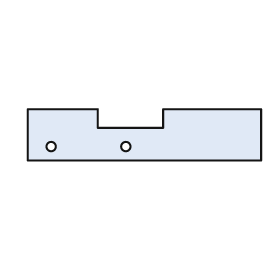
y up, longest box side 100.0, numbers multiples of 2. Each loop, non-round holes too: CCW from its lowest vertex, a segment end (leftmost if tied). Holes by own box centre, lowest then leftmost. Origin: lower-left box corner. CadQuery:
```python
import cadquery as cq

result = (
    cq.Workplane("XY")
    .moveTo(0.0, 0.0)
    .lineTo(100.0, 0.0)
    .lineTo(100.0, 22.0)
    .lineTo(58.0, 22.0)
    .lineTo(58.0, 14.0)
    .lineTo(30.0, 14.0)
    .lineTo(30.0, 22.0)
    .lineTo(0.0, 22.0)
    .close()
    .moveTo(10.0, 6.0)
    .circle(2.0)
    .moveTo(42.0, 6.0)
    .circle(2.0)
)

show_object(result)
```